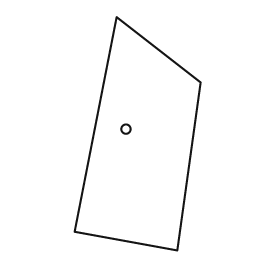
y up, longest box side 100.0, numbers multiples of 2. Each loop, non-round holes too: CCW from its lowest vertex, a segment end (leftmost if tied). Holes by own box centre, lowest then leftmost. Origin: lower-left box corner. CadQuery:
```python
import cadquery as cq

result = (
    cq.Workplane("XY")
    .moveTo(44.0, 0.0)
    .lineTo(54.0, 72.0)
    .lineTo(18.0, 100.0)
    .lineTo(0.0, 8.0)
    .close()
    .moveTo(22.0, 52.0)
    .circle(2.0)
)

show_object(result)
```